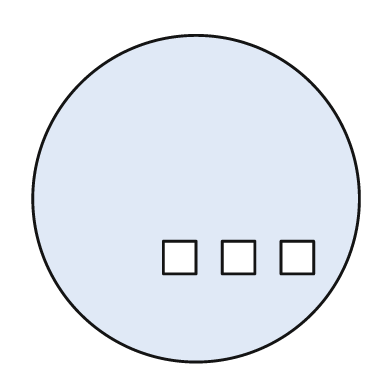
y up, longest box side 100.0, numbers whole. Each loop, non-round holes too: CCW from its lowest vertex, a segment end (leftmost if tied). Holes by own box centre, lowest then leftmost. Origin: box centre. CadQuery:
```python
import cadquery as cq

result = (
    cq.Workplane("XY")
    .moveTo(0.0, 0.0)
    .circle(50.0)
    .moveTo(-10.0, -23.0)
    .lineTo(0.0, -23.0)
    .lineTo(0.0, -13.0)
    .lineTo(-10.0, -13.0)
    .close()
    .moveTo(8.0, -23.0)
    .lineTo(18.0, -23.0)
    .lineTo(18.0, -13.0)
    .lineTo(8.0, -13.0)
    .close()
    .moveTo(26.0, -23.0)
    .lineTo(36.0, -23.0)
    .lineTo(36.0, -13.0)
    .lineTo(26.0, -13.0)
    .close()
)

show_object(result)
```